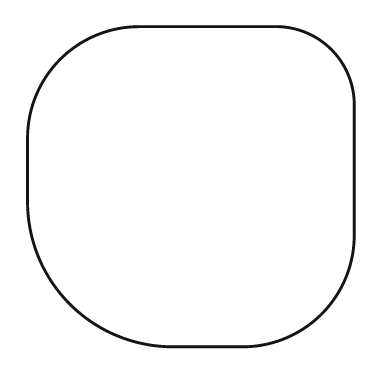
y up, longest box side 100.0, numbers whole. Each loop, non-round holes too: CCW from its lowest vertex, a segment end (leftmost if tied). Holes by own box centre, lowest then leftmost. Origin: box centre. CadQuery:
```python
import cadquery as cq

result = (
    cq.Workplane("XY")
    .moveTo(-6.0, -49.0)
    .lineTo(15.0, -49.0)
    .threePointArc((40.0, -39.0), (50.0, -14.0))
    .lineTo(50.0, 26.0)
    .threePointArc((43.0, 42.0), (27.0, 49.0))
    .lineTo(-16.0, 49.0)
    .threePointArc((-40.0, 39.0), (-50.0, 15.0))
    .lineTo(-50.0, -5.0)
    .threePointArc((-37.0, -36.0), (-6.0, -49.0))
    .close()
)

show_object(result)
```